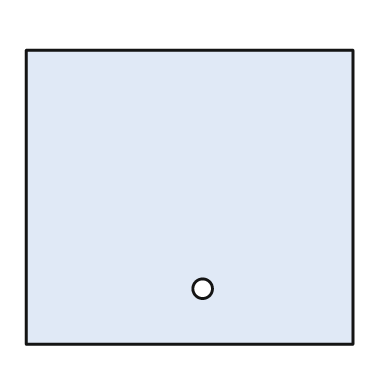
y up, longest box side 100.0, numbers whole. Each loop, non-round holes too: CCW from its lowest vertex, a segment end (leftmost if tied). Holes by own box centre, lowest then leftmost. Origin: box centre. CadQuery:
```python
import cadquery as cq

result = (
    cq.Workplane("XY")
    .moveTo(-50.0, -45.0)
    .lineTo(50.0, -45.0)
    .lineTo(50.0, 45.0)
    .lineTo(-50.0, 45.0)
    .close()
    .moveTo(4.0, -28.0)
    .circle(3.0)
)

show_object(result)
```